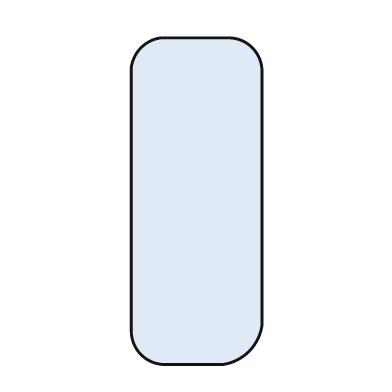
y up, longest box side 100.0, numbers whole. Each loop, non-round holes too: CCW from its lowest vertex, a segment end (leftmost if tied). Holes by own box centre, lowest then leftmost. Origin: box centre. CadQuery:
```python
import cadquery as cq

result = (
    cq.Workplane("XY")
    .moveTo(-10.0, -50.0)
    .lineTo(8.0, -50.0)
    .threePointArc((16.0, -46.0), (20.0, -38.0))
    .lineTo(20.0, 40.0)
    .threePointArc((17.0, 47.0), (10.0, 50.0))
    .lineTo(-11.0, 50.0)
    .threePointArc((-17.0, 47.0), (-20.0, 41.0))
    .lineTo(-20.0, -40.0)
    .threePointArc((-17.0, -47.0), (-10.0, -50.0))
    .close()
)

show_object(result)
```